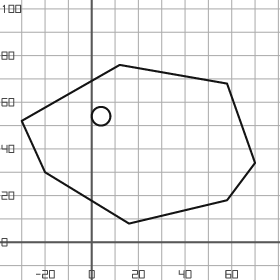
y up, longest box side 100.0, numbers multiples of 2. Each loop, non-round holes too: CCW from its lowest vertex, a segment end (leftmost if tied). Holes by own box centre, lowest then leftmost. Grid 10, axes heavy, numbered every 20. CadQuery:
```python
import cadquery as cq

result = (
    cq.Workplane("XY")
    .moveTo(16.0, 8.0)
    .lineTo(58.0, 18.0)
    .lineTo(70.0, 34.0)
    .lineTo(58.0, 68.0)
    .lineTo(12.0, 76.0)
    .lineTo(-30.0, 52.0)
    .lineTo(-20.0, 30.0)
    .close()
    .moveTo(4.0, 54.0)
    .circle(4.0)
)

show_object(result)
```